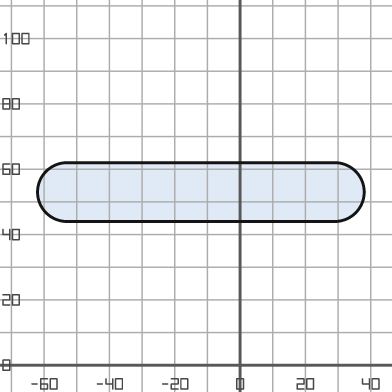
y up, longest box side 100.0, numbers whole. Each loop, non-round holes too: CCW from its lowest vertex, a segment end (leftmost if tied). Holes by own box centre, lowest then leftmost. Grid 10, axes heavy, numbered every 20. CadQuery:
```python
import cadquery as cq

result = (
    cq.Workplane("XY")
    .moveTo(-53.0, 44.0)
    .lineTo(29.0, 44.0)
    .threePointArc((38.0, 53.0), (29.0, 62.0))
    .lineTo(-53.0, 62.0)
    .threePointArc((-62.0, 53.0), (-53.0, 44.0))
    .close()
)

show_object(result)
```